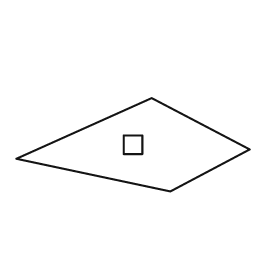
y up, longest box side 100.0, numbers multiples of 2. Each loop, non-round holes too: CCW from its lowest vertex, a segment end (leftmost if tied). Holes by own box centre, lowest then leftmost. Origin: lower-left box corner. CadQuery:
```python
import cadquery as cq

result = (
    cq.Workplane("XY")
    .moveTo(66.0, 0.0)
    .lineTo(100.0, 18.0)
    .lineTo(58.0, 40.0)
    .lineTo(0.0, 14.0)
    .close()
    .moveTo(46.0, 16.0)
    .lineTo(54.0, 16.0)
    .lineTo(54.0, 24.0)
    .lineTo(46.0, 24.0)
    .close()
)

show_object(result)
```